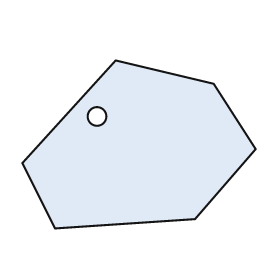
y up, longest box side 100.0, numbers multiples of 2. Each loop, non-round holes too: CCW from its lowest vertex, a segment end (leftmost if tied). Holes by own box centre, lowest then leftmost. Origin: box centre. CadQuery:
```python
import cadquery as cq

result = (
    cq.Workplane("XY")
    .moveTo(-36.0, -36.0)
    .lineTo(24.0, -32.0)
    .lineTo(50.0, -2.0)
    .lineTo(32.0, 26.0)
    .lineTo(-10.0, 36.0)
    .lineTo(-50.0, -8.0)
    .close()
    .moveTo(-18.0, 12.0)
    .circle(4.0)
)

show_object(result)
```